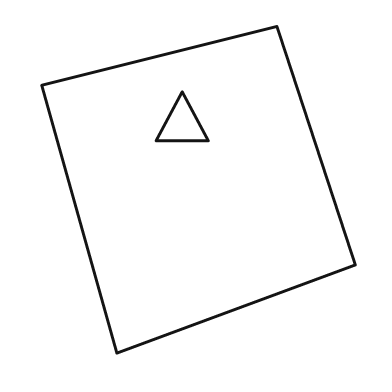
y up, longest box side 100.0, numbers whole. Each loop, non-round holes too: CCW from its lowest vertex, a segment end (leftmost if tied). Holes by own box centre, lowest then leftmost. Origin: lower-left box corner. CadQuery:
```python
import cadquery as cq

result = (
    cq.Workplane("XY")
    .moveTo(23.0, 0.0)
    .lineTo(96.0, 27.0)
    .lineTo(72.0, 100.0)
    .lineTo(0.0, 82.0)
    .close()
    .moveTo(35.0, 65.0)
    .lineTo(51.0, 65.0)
    .lineTo(43.0, 80.0)
    .close()
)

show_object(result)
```